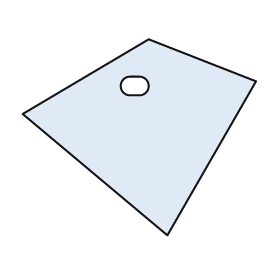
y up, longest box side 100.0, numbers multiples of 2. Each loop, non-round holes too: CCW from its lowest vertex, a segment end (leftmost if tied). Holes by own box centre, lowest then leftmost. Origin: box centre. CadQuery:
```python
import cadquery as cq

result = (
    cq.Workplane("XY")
    .moveTo(12.0, -42.0)
    .lineTo(50.0, 24.0)
    .lineTo(4.0, 42.0)
    .lineTo(-50.0, 10.0)
    .close()
    .moveTo(-4.0, 18.0)
    .lineTo(0.0, 18.0)
    .threePointArc((4.0, 22.0), (0.0, 26.0))
    .lineTo(-4.0, 26.0)
    .threePointArc((-8.0, 22.0), (-4.0, 18.0))
    .close()
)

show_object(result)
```